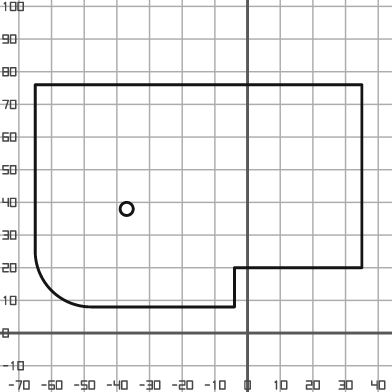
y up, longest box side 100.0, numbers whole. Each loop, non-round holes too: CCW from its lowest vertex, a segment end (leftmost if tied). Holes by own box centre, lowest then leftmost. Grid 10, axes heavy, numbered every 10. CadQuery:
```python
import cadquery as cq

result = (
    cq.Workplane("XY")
    .moveTo(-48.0, 8.0)
    .lineTo(-4.0, 8.0)
    .lineTo(-4.0, 20.0)
    .lineTo(35.0, 20.0)
    .lineTo(35.0, 76.0)
    .lineTo(-65.0, 76.0)
    .lineTo(-65.0, 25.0)
    .threePointArc((-60.0, 13.0), (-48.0, 8.0))
    .close()
    .moveTo(-37.0, 38.0)
    .circle(2.0)
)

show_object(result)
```